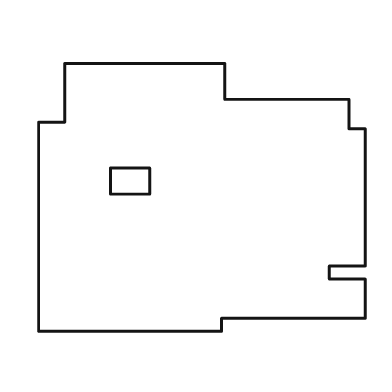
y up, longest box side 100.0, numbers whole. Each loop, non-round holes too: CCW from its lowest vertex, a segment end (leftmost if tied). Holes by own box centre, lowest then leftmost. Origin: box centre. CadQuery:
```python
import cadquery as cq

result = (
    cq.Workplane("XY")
    .moveTo(-50.0, -41.0)
    .lineTo(6.0, -41.0)
    .lineTo(6.0, -37.0)
    .lineTo(50.0, -37.0)
    .lineTo(50.0, -25.0)
    .lineTo(39.0, -25.0)
    .lineTo(39.0, -21.0)
    .lineTo(50.0, -21.0)
    .lineTo(50.0, 21.0)
    .lineTo(45.0, 21.0)
    .lineTo(45.0, 30.0)
    .lineTo(7.0, 30.0)
    .lineTo(7.0, 41.0)
    .lineTo(-42.0, 41.0)
    .lineTo(-42.0, 23.0)
    .lineTo(-50.0, 23.0)
    .close()
    .moveTo(-28.0, 1.0)
    .lineTo(-16.0, 1.0)
    .lineTo(-16.0, 9.0)
    .lineTo(-28.0, 9.0)
    .close()
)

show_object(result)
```